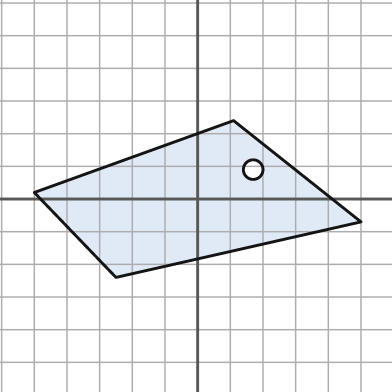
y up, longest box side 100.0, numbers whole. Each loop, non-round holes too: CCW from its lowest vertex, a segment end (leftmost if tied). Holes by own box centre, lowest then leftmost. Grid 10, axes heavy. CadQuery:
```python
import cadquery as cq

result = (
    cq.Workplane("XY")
    .moveTo(-25.0, -24.0)
    .lineTo(50.0, -7.0)
    .lineTo(11.0, 24.0)
    .lineTo(-50.0, 2.0)
    .close()
    .moveTo(17.0, 9.0)
    .circle(3.0)
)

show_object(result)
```